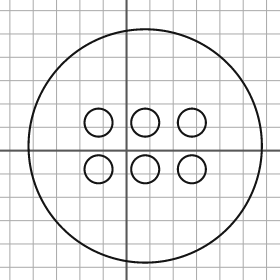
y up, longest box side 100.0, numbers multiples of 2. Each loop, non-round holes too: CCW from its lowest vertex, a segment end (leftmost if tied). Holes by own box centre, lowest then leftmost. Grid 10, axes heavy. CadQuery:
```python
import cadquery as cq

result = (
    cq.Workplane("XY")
    .moveTo(8.0, 2.0)
    .circle(50.0)
    .moveTo(-12.0, -8.0)
    .circle(6.0)
    .moveTo(8.0, -8.0)
    .circle(6.0)
    .moveTo(28.0, -8.0)
    .circle(6.0)
    .moveTo(-12.0, 12.0)
    .circle(6.0)
    .moveTo(8.0, 12.0)
    .circle(6.0)
    .moveTo(28.0, 12.0)
    .circle(6.0)
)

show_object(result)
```